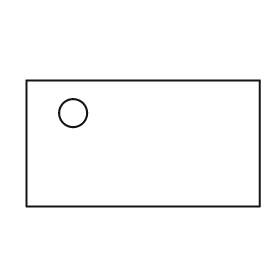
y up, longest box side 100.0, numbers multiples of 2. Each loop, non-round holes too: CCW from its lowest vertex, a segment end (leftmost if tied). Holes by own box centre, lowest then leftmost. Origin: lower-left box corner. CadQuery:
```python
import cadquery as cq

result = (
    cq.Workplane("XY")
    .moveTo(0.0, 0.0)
    .lineTo(100.0, 0.0)
    .lineTo(100.0, 54.0)
    .lineTo(0.0, 54.0)
    .close()
    .moveTo(20.0, 40.0)
    .circle(6.0)
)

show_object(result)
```